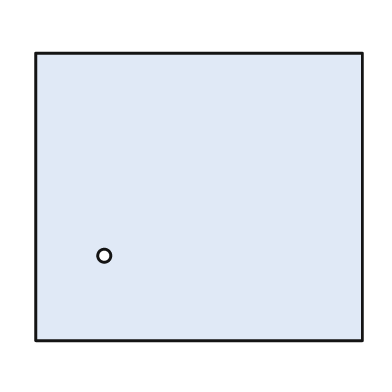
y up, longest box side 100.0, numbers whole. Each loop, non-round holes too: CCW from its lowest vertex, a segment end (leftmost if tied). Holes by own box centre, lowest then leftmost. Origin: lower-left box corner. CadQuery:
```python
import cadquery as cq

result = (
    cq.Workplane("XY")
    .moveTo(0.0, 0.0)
    .lineTo(100.0, 0.0)
    .lineTo(100.0, 88.0)
    .lineTo(0.0, 88.0)
    .close()
    .moveTo(21.0, 26.0)
    .circle(2.0)
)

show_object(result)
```